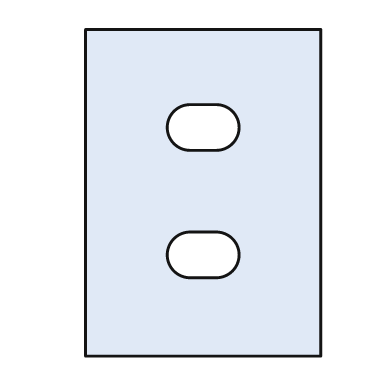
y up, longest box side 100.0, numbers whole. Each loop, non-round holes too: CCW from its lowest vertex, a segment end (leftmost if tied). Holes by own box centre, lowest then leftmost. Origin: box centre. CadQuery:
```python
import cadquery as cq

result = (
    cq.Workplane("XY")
    .moveTo(-36.0, -50.0)
    .lineTo(36.0, -50.0)
    .lineTo(36.0, 50.0)
    .lineTo(-36.0, 50.0)
    .close()
    .moveTo(-4.0, -26.0)
    .lineTo(4.0, -26.0)
    .threePointArc((11.0, -19.0), (4.0, -12.0))
    .lineTo(-4.0, -12.0)
    .threePointArc((-11.0, -19.0), (-4.0, -26.0))
    .close()
    .moveTo(-4.0, 13.0)
    .lineTo(4.0, 13.0)
    .threePointArc((11.0, 20.0), (4.0, 27.0))
    .lineTo(-4.0, 27.0)
    .threePointArc((-11.0, 20.0), (-4.0, 13.0))
    .close()
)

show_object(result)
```